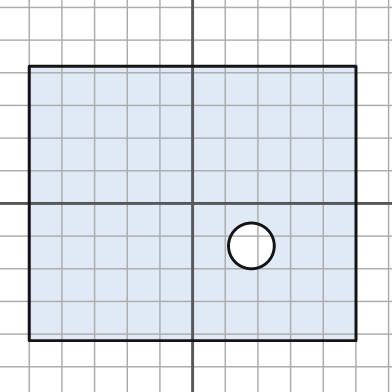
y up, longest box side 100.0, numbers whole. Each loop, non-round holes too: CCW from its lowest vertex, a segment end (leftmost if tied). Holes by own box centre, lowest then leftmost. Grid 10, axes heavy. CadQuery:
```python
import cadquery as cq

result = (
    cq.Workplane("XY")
    .moveTo(-50.0, -42.0)
    .lineTo(50.0, -42.0)
    .lineTo(50.0, 42.0)
    .lineTo(-50.0, 42.0)
    .close()
    .moveTo(18.0, -13.0)
    .circle(7.0)
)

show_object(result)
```